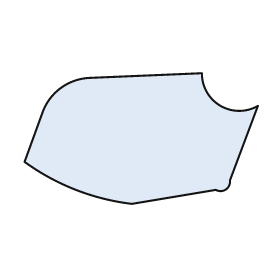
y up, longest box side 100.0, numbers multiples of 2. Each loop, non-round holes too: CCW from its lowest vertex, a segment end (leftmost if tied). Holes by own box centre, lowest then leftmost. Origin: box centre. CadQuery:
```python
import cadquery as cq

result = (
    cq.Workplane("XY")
    .moveTo(-4.0, -28.0)
    .lineTo(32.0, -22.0)
    .threePointArc((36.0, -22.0), (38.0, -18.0))
    .lineTo(50.0, 14.0)
    .threePointArc((34.0, 14.0), (26.0, 28.0))
    .lineTo(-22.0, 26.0)
    .threePointArc((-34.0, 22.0), (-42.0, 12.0))
    .lineTo(-50.0, -10.0)
    .threePointArc((-28.0, -22.0), (-4.0, -28.0))
    .close()
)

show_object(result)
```